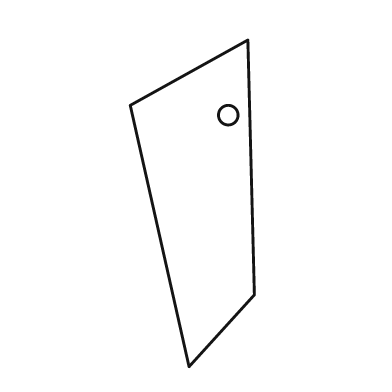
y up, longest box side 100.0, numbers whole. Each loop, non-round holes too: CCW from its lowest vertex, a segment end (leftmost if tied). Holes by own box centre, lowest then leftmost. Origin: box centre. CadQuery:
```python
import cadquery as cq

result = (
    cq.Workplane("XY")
    .moveTo(-1.0, -50.0)
    .lineTo(19.0, -28.0)
    .lineTo(17.0, 50.0)
    .lineTo(-19.0, 30.0)
    .close()
    .moveTo(11.0, 27.0)
    .circle(3.0)
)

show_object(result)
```